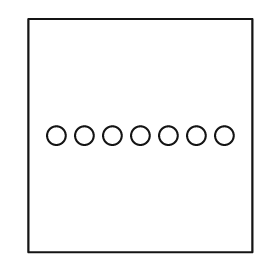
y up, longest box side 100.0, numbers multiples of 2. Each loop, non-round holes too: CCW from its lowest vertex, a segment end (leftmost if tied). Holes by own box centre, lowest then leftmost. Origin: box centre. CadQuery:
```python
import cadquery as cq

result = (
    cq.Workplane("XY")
    .moveTo(-48.0, -50.0)
    .lineTo(48.0, -50.0)
    .lineTo(48.0, 50.0)
    .lineTo(-48.0, 50.0)
    .close()
    .moveTo(-36.0, 0.0)
    .circle(4.0)
    .moveTo(-24.0, 0.0)
    .circle(4.0)
    .moveTo(-12.0, 0.0)
    .circle(4.0)
    .moveTo(0.0, 0.0)
    .circle(4.0)
    .moveTo(12.0, 0.0)
    .circle(4.0)
    .moveTo(24.0, 0.0)
    .circle(4.0)
    .moveTo(36.0, 0.0)
    .circle(4.0)
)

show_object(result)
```